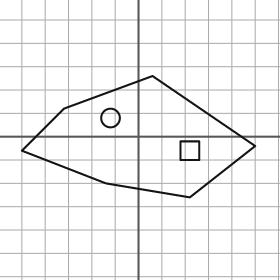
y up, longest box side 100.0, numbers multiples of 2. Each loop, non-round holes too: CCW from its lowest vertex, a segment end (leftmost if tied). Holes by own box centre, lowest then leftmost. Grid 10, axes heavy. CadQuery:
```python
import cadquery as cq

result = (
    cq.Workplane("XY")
    .moveTo(22.0, -26.0)
    .lineTo(50.0, -4.0)
    .lineTo(6.0, 26.0)
    .lineTo(-32.0, 12.0)
    .lineTo(-50.0, -6.0)
    .lineTo(-14.0, -20.0)
    .close()
    .moveTo(18.0, -10.0)
    .lineTo(26.0, -10.0)
    .lineTo(26.0, -2.0)
    .lineTo(18.0, -2.0)
    .close()
    .moveTo(-12.0, 8.0)
    .circle(4.0)
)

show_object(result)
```